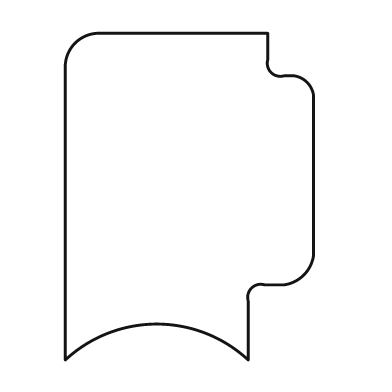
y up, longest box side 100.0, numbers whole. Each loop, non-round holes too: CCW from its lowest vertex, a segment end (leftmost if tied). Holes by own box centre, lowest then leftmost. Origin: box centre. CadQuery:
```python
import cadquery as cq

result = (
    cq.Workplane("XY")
    .moveTo(-38.0, -50.0)
    .threePointArc((-10.0, -39.0), (18.0, -50.0))
    .lineTo(18.0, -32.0)
    .threePointArc((19.0, -28.0), (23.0, -27.0))
    .lineTo(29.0, -27.0)
    .threePointArc((35.0, -24.0), (38.0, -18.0))
    .lineTo(38.0, 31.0)
    .threePointArc((36.0, 35.0), (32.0, 37.0))
    .lineTo(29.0, 37.0)
    .threePointArc((25.0, 38.0), (24.0, 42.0))
    .lineTo(24.0, 50.0)
    .lineTo(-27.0, 50.0)
    .threePointArc((-35.0, 47.0), (-38.0, 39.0))
    .close()
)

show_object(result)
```